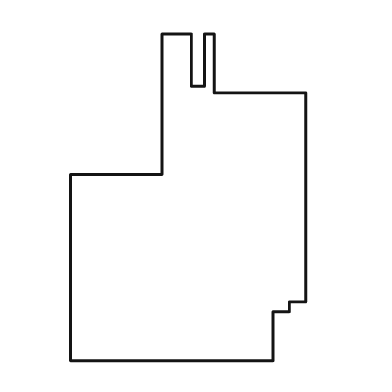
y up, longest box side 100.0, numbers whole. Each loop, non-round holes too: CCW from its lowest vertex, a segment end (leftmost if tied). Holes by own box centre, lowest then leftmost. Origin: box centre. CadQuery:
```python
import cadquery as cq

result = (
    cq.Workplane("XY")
    .moveTo(-36.0, -50.0)
    .lineTo(26.0, -50.0)
    .lineTo(26.0, -35.0)
    .lineTo(31.0, -35.0)
    .lineTo(31.0, -32.0)
    .lineTo(36.0, -32.0)
    .lineTo(36.0, 32.0)
    .lineTo(8.0, 32.0)
    .lineTo(8.0, 50.0)
    .lineTo(5.0, 50.0)
    .lineTo(5.0, 34.0)
    .lineTo(1.0, 34.0)
    .lineTo(1.0, 50.0)
    .lineTo(-8.0, 50.0)
    .lineTo(-8.0, 7.0)
    .lineTo(-36.0, 7.0)
    .close()
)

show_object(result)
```